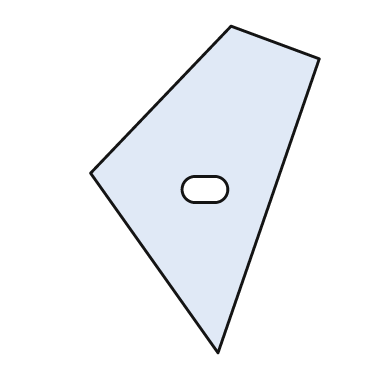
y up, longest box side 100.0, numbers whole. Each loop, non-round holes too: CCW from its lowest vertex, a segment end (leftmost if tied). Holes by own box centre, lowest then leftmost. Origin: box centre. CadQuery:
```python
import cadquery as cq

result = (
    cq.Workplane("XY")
    .moveTo(4.0, -50.0)
    .lineTo(35.0, 40.0)
    .lineTo(8.0, 50.0)
    .lineTo(-35.0, 5.0)
    .close()
    .moveTo(-3.0, -4.0)
    .lineTo(3.0, -4.0)
    .threePointArc((7.0, 0.0), (3.0, 4.0))
    .lineTo(-3.0, 4.0)
    .threePointArc((-7.0, 0.0), (-3.0, -4.0))
    .close()
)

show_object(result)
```